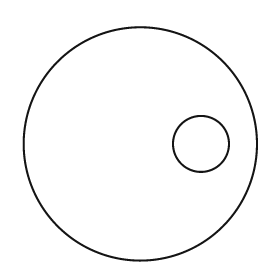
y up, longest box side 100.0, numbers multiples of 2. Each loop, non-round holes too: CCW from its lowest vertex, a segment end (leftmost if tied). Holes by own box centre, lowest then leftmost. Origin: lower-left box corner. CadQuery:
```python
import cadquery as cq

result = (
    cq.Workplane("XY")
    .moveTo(50.0, 50.0)
    .circle(50.0)
    .moveTo(76.0, 50.0)
    .circle(12.0)
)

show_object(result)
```